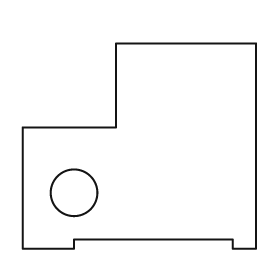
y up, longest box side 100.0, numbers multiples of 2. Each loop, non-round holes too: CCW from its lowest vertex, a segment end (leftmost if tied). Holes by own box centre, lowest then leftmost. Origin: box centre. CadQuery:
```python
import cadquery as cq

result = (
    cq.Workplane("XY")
    .moveTo(-50.0, -44.0)
    .lineTo(-28.0, -44.0)
    .lineTo(-28.0, -40.0)
    .lineTo(40.0, -40.0)
    .lineTo(40.0, -44.0)
    .lineTo(50.0, -44.0)
    .lineTo(50.0, 44.0)
    .lineTo(-10.0, 44.0)
    .lineTo(-10.0, 8.0)
    .lineTo(-50.0, 8.0)
    .close()
    .moveTo(-28.0, -20.0)
    .circle(10.0)
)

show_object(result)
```